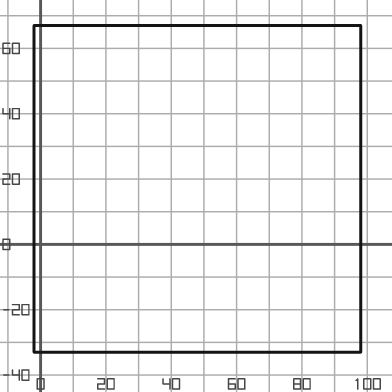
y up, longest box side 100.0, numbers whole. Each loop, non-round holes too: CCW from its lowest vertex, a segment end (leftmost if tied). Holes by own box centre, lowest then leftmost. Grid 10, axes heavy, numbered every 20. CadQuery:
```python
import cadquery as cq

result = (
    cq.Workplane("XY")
    .moveTo(-2.0, -33.0)
    .lineTo(98.0, -33.0)
    .lineTo(98.0, 67.0)
    .lineTo(-2.0, 67.0)
    .close()
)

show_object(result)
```